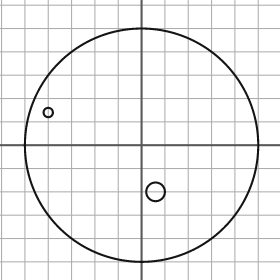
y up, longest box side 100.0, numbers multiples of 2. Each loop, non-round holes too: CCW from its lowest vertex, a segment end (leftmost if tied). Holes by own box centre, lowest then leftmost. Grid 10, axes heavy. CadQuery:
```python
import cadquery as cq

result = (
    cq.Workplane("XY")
    .moveTo(0.0, 0.0)
    .circle(50.0)
    .moveTo(6.0, -20.0)
    .circle(4.0)
    .moveTo(-40.0, 14.0)
    .circle(2.0)
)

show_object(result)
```